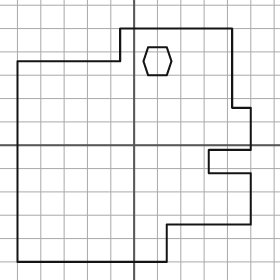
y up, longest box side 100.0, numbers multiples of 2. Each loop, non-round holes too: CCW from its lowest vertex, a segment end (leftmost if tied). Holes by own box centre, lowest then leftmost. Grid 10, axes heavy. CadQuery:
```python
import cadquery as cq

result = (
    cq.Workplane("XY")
    .moveTo(-50.0, -50.0)
    .lineTo(14.0, -50.0)
    .lineTo(14.0, -34.0)
    .lineTo(50.0, -34.0)
    .lineTo(50.0, -12.0)
    .lineTo(32.0, -12.0)
    .lineTo(32.0, -2.0)
    .lineTo(50.0, -2.0)
    .lineTo(50.0, 16.0)
    .lineTo(42.0, 16.0)
    .lineTo(42.0, 50.0)
    .lineTo(-6.0, 50.0)
    .lineTo(-6.0, 36.0)
    .lineTo(-50.0, 36.0)
    .close()
    .moveTo(6.0, 30.0)
    .lineTo(14.0, 30.0)
    .lineTo(16.0, 36.0)
    .lineTo(14.0, 42.0)
    .lineTo(6.0, 42.0)
    .lineTo(4.0, 36.0)
    .close()
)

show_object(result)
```